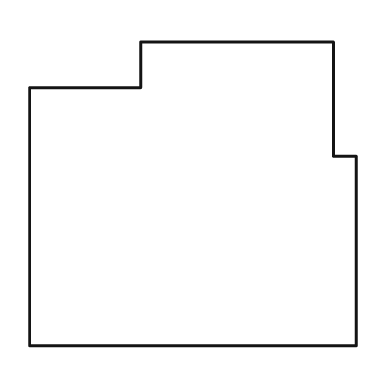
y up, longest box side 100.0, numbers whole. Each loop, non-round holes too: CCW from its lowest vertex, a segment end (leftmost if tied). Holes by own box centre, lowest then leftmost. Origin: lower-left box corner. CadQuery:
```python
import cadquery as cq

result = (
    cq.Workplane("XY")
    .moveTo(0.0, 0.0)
    .lineTo(100.0, 0.0)
    .lineTo(100.0, 58.0)
    .lineTo(93.0, 58.0)
    .lineTo(93.0, 93.0)
    .lineTo(34.0, 93.0)
    .lineTo(34.0, 79.0)
    .lineTo(0.0, 79.0)
    .close()
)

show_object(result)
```